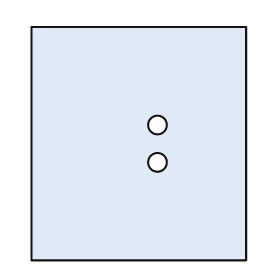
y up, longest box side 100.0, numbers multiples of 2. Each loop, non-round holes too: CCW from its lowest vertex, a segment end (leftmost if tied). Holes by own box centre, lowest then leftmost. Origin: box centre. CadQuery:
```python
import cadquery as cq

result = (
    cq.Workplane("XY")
    .moveTo(-46.0, -50.0)
    .lineTo(46.0, -50.0)
    .lineTo(46.0, 50.0)
    .lineTo(-46.0, 50.0)
    .close()
    .moveTo(8.0, -8.0)
    .circle(4.0)
    .moveTo(8.0, 8.0)
    .circle(4.0)
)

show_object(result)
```